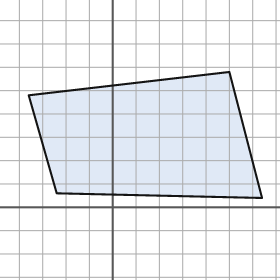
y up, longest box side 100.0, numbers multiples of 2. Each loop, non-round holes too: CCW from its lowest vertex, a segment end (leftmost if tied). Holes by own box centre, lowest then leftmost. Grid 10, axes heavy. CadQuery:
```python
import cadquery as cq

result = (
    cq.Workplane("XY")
    .moveTo(64.0, 4.0)
    .lineTo(50.0, 58.0)
    .lineTo(-36.0, 48.0)
    .lineTo(-24.0, 6.0)
    .close()
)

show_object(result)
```